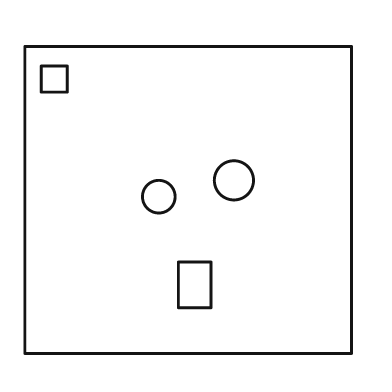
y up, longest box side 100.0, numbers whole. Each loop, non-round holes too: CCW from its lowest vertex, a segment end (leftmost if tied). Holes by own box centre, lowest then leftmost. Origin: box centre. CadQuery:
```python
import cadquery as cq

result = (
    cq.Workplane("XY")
    .moveTo(-50.0, -47.0)
    .lineTo(50.0, -47.0)
    .lineTo(50.0, 47.0)
    .lineTo(-50.0, 47.0)
    .close()
    .moveTo(-3.0, -33.0)
    .lineTo(7.0, -33.0)
    .lineTo(7.0, -19.0)
    .lineTo(-3.0, -19.0)
    .close()
    .moveTo(-9.0, 1.0)
    .circle(5.0)
    .moveTo(14.0, 6.0)
    .circle(6.0)
    .moveTo(-45.0, 33.0)
    .lineTo(-37.0, 33.0)
    .lineTo(-37.0, 41.0)
    .lineTo(-45.0, 41.0)
    .close()
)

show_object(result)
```